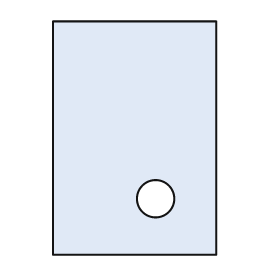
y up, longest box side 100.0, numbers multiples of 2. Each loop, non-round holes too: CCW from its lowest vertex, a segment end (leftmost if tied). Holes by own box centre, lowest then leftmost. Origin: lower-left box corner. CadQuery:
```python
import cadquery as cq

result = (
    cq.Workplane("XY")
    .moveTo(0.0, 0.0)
    .lineTo(70.0, 0.0)
    .lineTo(70.0, 100.0)
    .lineTo(0.0, 100.0)
    .close()
    .moveTo(44.0, 24.0)
    .circle(8.0)
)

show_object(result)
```